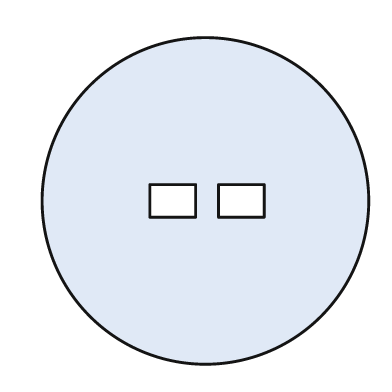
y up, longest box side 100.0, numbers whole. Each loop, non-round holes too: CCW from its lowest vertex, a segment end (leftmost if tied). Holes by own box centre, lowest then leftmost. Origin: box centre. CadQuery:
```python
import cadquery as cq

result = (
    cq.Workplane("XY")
    .moveTo(0.0, 0.0)
    .circle(50.0)
    .moveTo(-17.0, -5.0)
    .lineTo(-3.0, -5.0)
    .lineTo(-3.0, 5.0)
    .lineTo(-17.0, 5.0)
    .close()
    .moveTo(4.0, -5.0)
    .lineTo(18.0, -5.0)
    .lineTo(18.0, 5.0)
    .lineTo(4.0, 5.0)
    .close()
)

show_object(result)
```